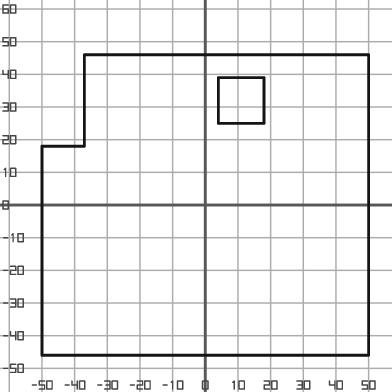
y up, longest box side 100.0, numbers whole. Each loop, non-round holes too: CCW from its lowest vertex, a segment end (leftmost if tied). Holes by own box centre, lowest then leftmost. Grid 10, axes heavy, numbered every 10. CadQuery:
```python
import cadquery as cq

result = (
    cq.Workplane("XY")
    .moveTo(-50.0, -46.0)
    .lineTo(50.0, -46.0)
    .lineTo(50.0, 46.0)
    .lineTo(-37.0, 46.0)
    .lineTo(-37.0, 18.0)
    .lineTo(-50.0, 18.0)
    .close()
    .moveTo(4.0, 25.0)
    .lineTo(18.0, 25.0)
    .lineTo(18.0, 39.0)
    .lineTo(4.0, 39.0)
    .close()
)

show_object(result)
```